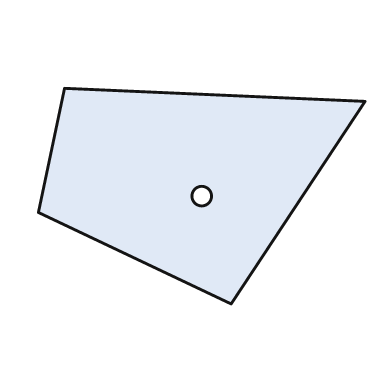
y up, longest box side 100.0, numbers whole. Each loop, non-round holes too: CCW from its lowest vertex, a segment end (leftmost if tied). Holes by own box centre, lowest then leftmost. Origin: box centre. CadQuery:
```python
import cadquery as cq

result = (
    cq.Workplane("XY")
    .moveTo(9.0, -33.0)
    .lineTo(50.0, 29.0)
    .lineTo(-42.0, 33.0)
    .lineTo(-50.0, -5.0)
    .close()
    .moveTo(0.0, 0.0)
    .circle(3.0)
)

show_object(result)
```